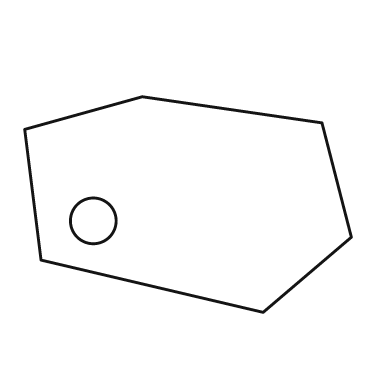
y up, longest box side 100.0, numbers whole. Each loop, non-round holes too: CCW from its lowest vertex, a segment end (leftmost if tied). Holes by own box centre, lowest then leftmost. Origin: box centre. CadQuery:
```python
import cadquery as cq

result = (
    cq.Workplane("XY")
    .moveTo(23.0, -33.0)
    .lineTo(50.0, -10.0)
    .lineTo(41.0, 25.0)
    .lineTo(-14.0, 33.0)
    .lineTo(-50.0, 23.0)
    .lineTo(-45.0, -17.0)
    .close()
    .moveTo(-29.0, -5.0)
    .circle(7.0)
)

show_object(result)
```